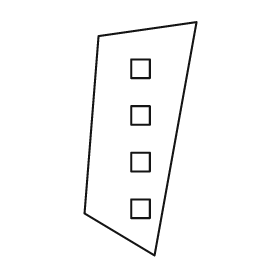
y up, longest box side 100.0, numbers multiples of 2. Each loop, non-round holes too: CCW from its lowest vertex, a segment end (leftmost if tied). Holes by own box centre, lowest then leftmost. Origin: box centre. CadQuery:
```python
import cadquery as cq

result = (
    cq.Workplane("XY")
    .moveTo(6.0, -50.0)
    .lineTo(24.0, 50.0)
    .lineTo(-18.0, 44.0)
    .lineTo(-24.0, -32.0)
    .close()
    .moveTo(-4.0, -34.0)
    .lineTo(4.0, -34.0)
    .lineTo(4.0, -26.0)
    .lineTo(-4.0, -26.0)
    .close()
    .moveTo(-4.0, -14.0)
    .lineTo(4.0, -14.0)
    .lineTo(4.0, -6.0)
    .lineTo(-4.0, -6.0)
    .close()
    .moveTo(-4.0, 6.0)
    .lineTo(4.0, 6.0)
    .lineTo(4.0, 14.0)
    .lineTo(-4.0, 14.0)
    .close()
    .moveTo(-4.0, 26.0)
    .lineTo(4.0, 26.0)
    .lineTo(4.0, 34.0)
    .lineTo(-4.0, 34.0)
    .close()
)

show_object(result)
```